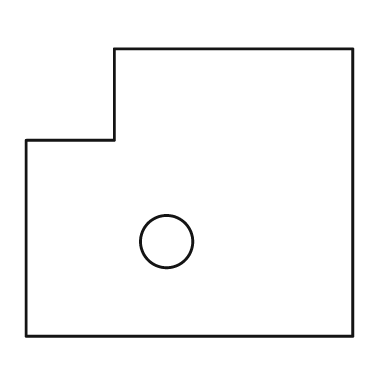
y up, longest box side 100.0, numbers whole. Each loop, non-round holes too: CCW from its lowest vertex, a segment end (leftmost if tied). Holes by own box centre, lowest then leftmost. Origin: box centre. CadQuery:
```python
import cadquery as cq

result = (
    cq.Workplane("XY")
    .moveTo(-50.0, -44.0)
    .lineTo(50.0, -44.0)
    .lineTo(50.0, 44.0)
    .lineTo(-23.0, 44.0)
    .lineTo(-23.0, 16.0)
    .lineTo(-50.0, 16.0)
    .close()
    .moveTo(-7.0, -15.0)
    .circle(8.0)
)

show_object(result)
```